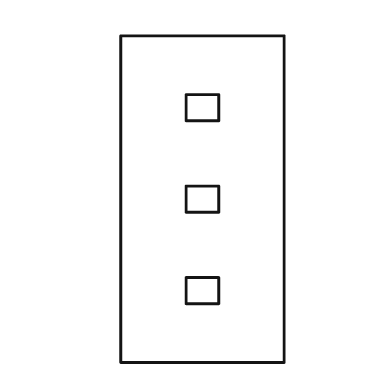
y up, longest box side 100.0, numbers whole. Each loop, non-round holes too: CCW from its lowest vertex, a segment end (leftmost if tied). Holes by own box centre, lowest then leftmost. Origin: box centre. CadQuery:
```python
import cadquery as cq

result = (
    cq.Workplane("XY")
    .moveTo(-25.0, -50.0)
    .lineTo(25.0, -50.0)
    .lineTo(25.0, 50.0)
    .lineTo(-25.0, 50.0)
    .close()
    .moveTo(-5.0, -32.0)
    .lineTo(5.0, -32.0)
    .lineTo(5.0, -24.0)
    .lineTo(-5.0, -24.0)
    .close()
    .moveTo(-5.0, -4.0)
    .lineTo(5.0, -4.0)
    .lineTo(5.0, 4.0)
    .lineTo(-5.0, 4.0)
    .close()
    .moveTo(-5.0, 24.0)
    .lineTo(5.0, 24.0)
    .lineTo(5.0, 32.0)
    .lineTo(-5.0, 32.0)
    .close()
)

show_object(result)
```